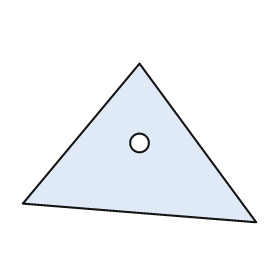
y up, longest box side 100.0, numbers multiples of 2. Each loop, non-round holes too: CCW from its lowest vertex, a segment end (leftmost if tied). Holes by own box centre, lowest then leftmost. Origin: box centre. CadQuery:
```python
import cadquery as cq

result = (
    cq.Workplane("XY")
    .moveTo(50.0, -34.0)
    .lineTo(0.0, 34.0)
    .lineTo(-50.0, -26.0)
    .close()
    .moveTo(0.0, 0.0)
    .circle(4.0)
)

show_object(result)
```